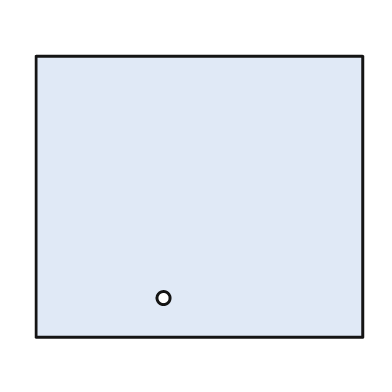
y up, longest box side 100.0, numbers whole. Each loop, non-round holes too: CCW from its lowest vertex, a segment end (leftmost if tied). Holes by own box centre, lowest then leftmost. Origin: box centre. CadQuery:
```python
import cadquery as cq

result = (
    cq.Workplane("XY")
    .moveTo(-50.0, -43.0)
    .lineTo(50.0, -43.0)
    .lineTo(50.0, 43.0)
    .lineTo(-50.0, 43.0)
    .close()
    .moveTo(-11.0, -31.0)
    .circle(2.0)
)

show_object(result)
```